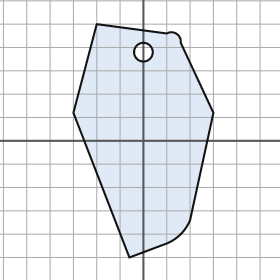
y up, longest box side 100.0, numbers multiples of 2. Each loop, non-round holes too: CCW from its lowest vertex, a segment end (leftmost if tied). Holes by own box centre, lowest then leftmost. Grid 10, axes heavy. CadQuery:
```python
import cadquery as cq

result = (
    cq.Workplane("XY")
    .moveTo(-6.0, -50.0)
    .lineTo(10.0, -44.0)
    .threePointArc((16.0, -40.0), (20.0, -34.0))
    .lineTo(30.0, 12.0)
    .lineTo(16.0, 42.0)
    .threePointArc((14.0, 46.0), (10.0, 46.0))
    .lineTo(-20.0, 50.0)
    .lineTo(-30.0, 12.0)
    .close()
    .moveTo(0.0, 38.0)
    .circle(4.0)
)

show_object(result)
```